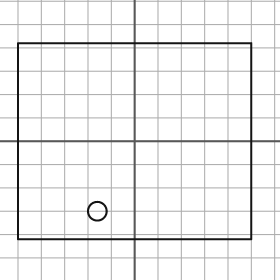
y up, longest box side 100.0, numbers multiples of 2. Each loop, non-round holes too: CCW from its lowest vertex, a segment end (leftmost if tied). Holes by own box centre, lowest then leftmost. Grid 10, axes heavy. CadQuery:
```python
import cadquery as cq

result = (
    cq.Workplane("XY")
    .moveTo(-50.0, -42.0)
    .lineTo(50.0, -42.0)
    .lineTo(50.0, 42.0)
    .lineTo(-50.0, 42.0)
    .close()
    .moveTo(-16.0, -30.0)
    .circle(4.0)
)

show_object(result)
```